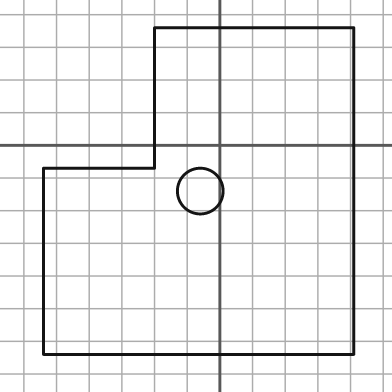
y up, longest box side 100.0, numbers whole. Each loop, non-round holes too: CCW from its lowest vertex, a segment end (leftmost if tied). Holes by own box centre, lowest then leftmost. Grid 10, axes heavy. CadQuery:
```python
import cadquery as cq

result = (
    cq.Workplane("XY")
    .moveTo(-54.0, -64.0)
    .lineTo(41.0, -64.0)
    .lineTo(41.0, 36.0)
    .lineTo(-20.0, 36.0)
    .lineTo(-20.0, -7.0)
    .lineTo(-54.0, -7.0)
    .close()
    .moveTo(-6.0, -14.0)
    .circle(7.0)
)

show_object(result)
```